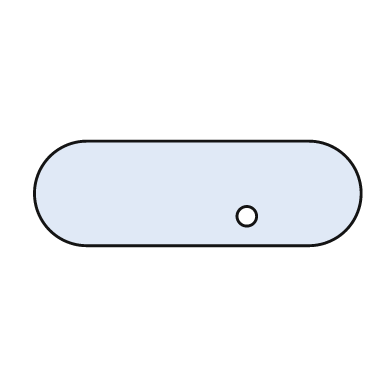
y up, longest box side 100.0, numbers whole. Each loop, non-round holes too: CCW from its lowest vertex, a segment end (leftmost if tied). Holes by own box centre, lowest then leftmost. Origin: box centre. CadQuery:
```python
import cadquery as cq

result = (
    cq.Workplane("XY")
    .moveTo(-34.0, -16.0)
    .lineTo(34.0, -16.0)
    .threePointArc((50.0, 0.0), (34.0, 16.0))
    .lineTo(-34.0, 16.0)
    .threePointArc((-50.0, 0.0), (-34.0, -16.0))
    .close()
    .moveTo(15.0, -7.0)
    .circle(3.0)
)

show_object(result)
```